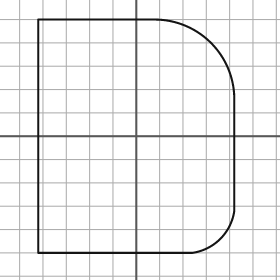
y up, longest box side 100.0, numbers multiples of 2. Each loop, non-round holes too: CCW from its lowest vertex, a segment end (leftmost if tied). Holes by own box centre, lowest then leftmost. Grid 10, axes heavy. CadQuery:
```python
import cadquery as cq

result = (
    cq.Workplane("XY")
    .moveTo(-42.0, -50.0)
    .lineTo(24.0, -50.0)
    .threePointArc((36.0, -44.0), (42.0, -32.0))
    .lineTo(42.0, 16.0)
    .threePointArc((32.0, 40.0), (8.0, 50.0))
    .lineTo(-42.0, 50.0)
    .close()
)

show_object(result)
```